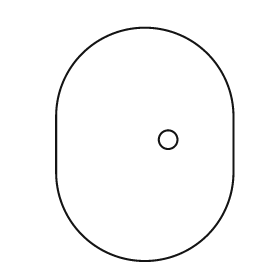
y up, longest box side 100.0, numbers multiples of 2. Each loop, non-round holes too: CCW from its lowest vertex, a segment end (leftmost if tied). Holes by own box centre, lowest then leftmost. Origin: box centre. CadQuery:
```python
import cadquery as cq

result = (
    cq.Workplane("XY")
    .moveTo(-38.0, -12.0)
    .threePointArc((0.0, -50.0), (38.0, -12.0))
    .lineTo(38.0, 12.0)
    .threePointArc((0.0, 50.0), (-38.0, 12.0))
    .close()
    .moveTo(10.0, 2.0)
    .circle(4.0)
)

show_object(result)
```